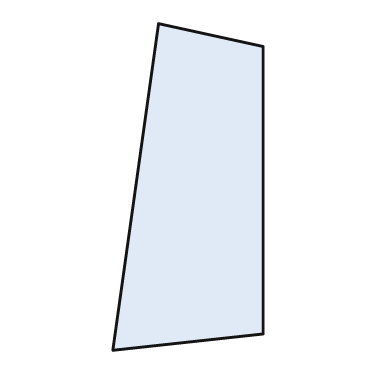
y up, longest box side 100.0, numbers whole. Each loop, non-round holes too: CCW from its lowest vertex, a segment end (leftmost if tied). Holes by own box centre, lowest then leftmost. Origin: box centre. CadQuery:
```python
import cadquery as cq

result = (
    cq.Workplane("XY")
    .moveTo(-23.0, -50.0)
    .lineTo(23.0, -45.0)
    .lineTo(23.0, 43.0)
    .lineTo(-9.0, 50.0)
    .close()
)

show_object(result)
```